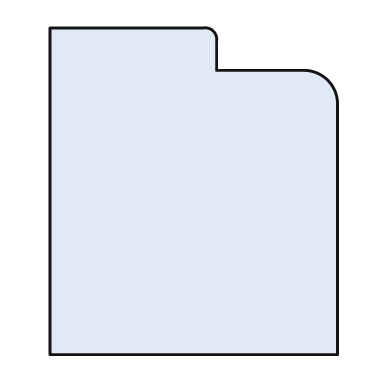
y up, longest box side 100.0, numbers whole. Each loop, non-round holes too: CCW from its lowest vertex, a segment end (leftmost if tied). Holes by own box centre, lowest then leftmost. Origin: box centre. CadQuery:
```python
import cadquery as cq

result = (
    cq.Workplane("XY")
    .moveTo(-44.0, -50.0)
    .lineTo(44.0, -50.0)
    .lineTo(44.0, 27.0)
    .threePointArc((41.0, 34.0), (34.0, 37.0))
    .lineTo(7.0, 37.0)
    .lineTo(7.0, 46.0)
    .threePointArc((6.0, 49.0), (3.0, 50.0))
    .lineTo(-44.0, 50.0)
    .close()
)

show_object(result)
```